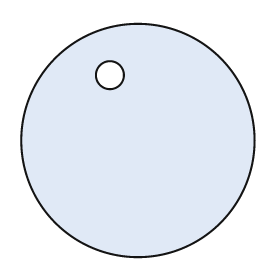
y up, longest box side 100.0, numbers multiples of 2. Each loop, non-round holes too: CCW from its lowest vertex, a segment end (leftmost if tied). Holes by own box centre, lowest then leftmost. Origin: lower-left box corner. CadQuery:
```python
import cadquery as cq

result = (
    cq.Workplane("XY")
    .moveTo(50.0, 50.0)
    .circle(50.0)
    .moveTo(38.0, 78.0)
    .circle(6.0)
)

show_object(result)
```